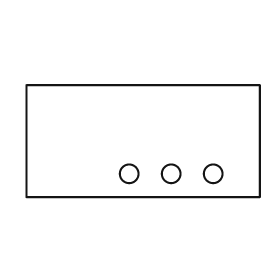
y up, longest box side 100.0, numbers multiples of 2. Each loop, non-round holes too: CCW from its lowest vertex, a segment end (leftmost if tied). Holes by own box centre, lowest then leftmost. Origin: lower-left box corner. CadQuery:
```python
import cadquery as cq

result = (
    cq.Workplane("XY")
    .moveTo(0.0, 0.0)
    .lineTo(100.0, 0.0)
    .lineTo(100.0, 48.0)
    .lineTo(0.0, 48.0)
    .close()
    .moveTo(44.0, 10.0)
    .circle(4.0)
    .moveTo(62.0, 10.0)
    .circle(4.0)
    .moveTo(80.0, 10.0)
    .circle(4.0)
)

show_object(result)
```